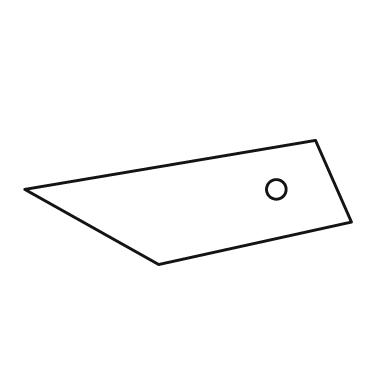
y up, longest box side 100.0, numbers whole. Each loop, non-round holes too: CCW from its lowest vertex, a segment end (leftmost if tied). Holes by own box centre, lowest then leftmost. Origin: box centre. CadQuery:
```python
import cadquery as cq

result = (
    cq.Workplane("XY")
    .moveTo(-9.0, -19.0)
    .lineTo(50.0, -6.0)
    .lineTo(39.0, 19.0)
    .lineTo(-50.0, 4.0)
    .close()
    .moveTo(27.0, 4.0)
    .circle(3.0)
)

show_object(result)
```